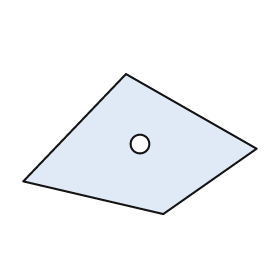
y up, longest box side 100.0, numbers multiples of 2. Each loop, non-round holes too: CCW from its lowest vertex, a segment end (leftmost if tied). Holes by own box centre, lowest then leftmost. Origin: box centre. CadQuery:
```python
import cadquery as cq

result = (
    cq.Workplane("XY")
    .moveTo(10.0, -30.0)
    .lineTo(50.0, -2.0)
    .lineTo(-6.0, 30.0)
    .lineTo(-50.0, -16.0)
    .close()
    .moveTo(0.0, 0.0)
    .circle(4.0)
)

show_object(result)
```